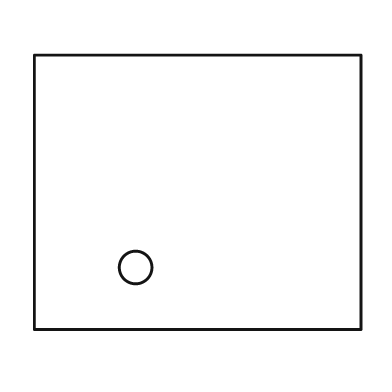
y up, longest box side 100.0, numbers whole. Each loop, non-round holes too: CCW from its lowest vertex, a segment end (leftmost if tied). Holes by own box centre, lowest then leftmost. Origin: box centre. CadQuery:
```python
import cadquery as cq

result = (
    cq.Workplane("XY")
    .moveTo(-50.0, -42.0)
    .lineTo(50.0, -42.0)
    .lineTo(50.0, 42.0)
    .lineTo(-50.0, 42.0)
    .close()
    .moveTo(-19.0, -23.0)
    .circle(5.0)
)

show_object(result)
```